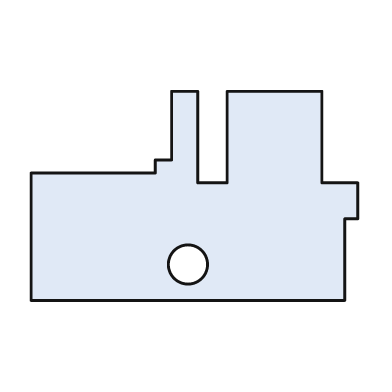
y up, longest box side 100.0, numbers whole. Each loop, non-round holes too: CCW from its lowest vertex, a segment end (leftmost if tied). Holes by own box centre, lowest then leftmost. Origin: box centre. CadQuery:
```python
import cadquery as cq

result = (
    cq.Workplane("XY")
    .moveTo(-50.0, -32.0)
    .lineTo(46.0, -32.0)
    .lineTo(46.0, -7.0)
    .lineTo(50.0, -7.0)
    .lineTo(50.0, 4.0)
    .lineTo(39.0, 4.0)
    .lineTo(39.0, 32.0)
    .lineTo(10.0, 32.0)
    .lineTo(10.0, 4.0)
    .lineTo(1.0, 4.0)
    .lineTo(1.0, 32.0)
    .lineTo(-7.0, 32.0)
    .lineTo(-7.0, 11.0)
    .lineTo(-12.0, 11.0)
    .lineTo(-12.0, 7.0)
    .lineTo(-50.0, 7.0)
    .close()
    .moveTo(-2.0, -21.0)
    .circle(6.0)
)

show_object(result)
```